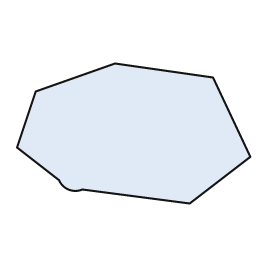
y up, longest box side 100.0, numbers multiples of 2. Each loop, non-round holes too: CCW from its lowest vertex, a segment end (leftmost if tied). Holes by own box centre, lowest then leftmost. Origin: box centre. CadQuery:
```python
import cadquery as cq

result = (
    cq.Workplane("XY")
    .moveTo(24.0, -30.0)
    .lineTo(50.0, -10.0)
    .lineTo(34.0, 24.0)
    .lineTo(-8.0, 30.0)
    .lineTo(-42.0, 18.0)
    .lineTo(-50.0, -6.0)
    .lineTo(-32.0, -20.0)
    .threePointArc((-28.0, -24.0), (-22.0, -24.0))
    .close()
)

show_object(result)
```